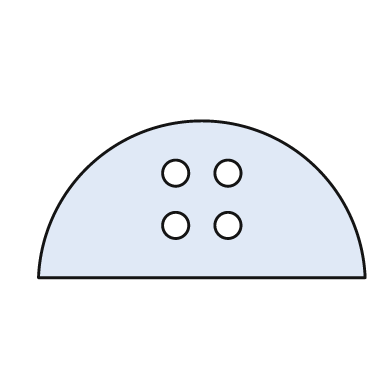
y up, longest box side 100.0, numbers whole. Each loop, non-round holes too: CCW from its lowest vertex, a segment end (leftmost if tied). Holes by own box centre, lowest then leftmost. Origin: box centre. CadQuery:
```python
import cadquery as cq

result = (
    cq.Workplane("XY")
    .moveTo(-50.0, -24.0)
    .lineTo(50.0, -24.0)
    .threePointArc((0.0, 24.0), (-50.0, -24.0))
    .close()
    .moveTo(-8.0, -8.0)
    .circle(4.0)
    .moveTo(8.0, -8.0)
    .circle(4.0)
    .moveTo(-8.0, 8.0)
    .circle(4.0)
    .moveTo(8.0, 8.0)
    .circle(4.0)
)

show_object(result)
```